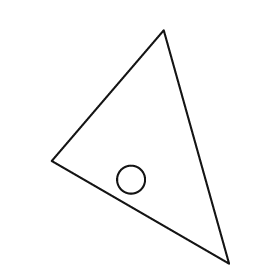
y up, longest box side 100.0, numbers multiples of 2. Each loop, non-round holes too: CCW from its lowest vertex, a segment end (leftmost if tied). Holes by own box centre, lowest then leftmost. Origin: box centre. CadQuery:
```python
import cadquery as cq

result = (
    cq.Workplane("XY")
    .moveTo(38.0, -50.0)
    .lineTo(10.0, 50.0)
    .lineTo(-38.0, -6.0)
    .close()
    .moveTo(-4.0, -14.0)
    .circle(6.0)
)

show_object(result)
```